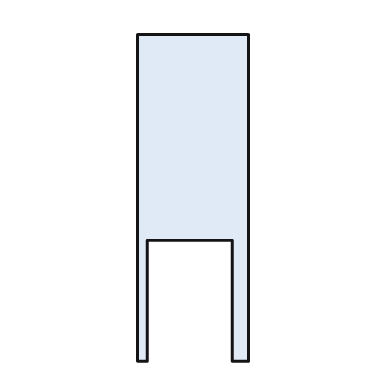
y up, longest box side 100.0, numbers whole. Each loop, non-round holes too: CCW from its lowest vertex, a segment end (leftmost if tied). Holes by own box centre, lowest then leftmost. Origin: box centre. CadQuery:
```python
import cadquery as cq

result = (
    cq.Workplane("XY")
    .moveTo(-17.0, -50.0)
    .lineTo(-14.0, -50.0)
    .lineTo(-14.0, -13.0)
    .lineTo(12.0, -13.0)
    .lineTo(12.0, -50.0)
    .lineTo(17.0, -50.0)
    .lineTo(17.0, 50.0)
    .lineTo(-17.0, 50.0)
    .close()
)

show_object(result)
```